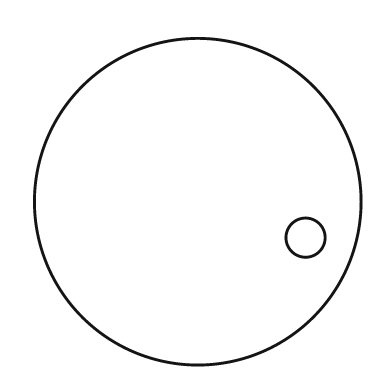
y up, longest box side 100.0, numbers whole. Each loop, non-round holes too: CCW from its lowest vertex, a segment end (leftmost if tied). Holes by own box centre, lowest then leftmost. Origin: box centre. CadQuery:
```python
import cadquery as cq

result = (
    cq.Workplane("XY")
    .moveTo(0.0, 0.0)
    .circle(50.0)
    .moveTo(33.0, -11.0)
    .circle(6.0)
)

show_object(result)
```